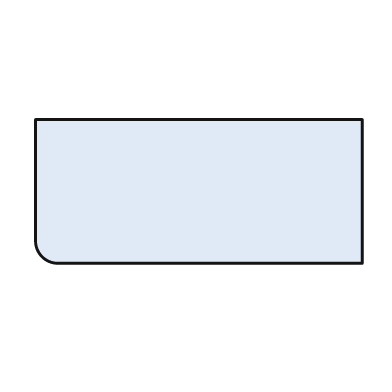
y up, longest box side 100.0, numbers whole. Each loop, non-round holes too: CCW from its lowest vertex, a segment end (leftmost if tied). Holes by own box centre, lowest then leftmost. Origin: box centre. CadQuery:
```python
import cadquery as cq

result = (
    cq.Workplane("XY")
    .moveTo(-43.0, -22.0)
    .lineTo(50.0, -22.0)
    .lineTo(50.0, 22.0)
    .lineTo(-50.0, 22.0)
    .lineTo(-50.0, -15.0)
    .threePointArc((-48.0, -20.0), (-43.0, -22.0))
    .close()
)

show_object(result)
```